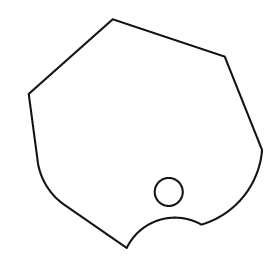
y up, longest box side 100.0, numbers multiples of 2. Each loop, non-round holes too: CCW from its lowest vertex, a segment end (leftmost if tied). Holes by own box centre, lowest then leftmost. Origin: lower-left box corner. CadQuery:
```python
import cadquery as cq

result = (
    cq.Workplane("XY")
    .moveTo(42.0, 0.0)
    .threePointArc((56.0, 12.0), (74.0, 10.0))
    .threePointArc((92.0, 22.0), (100.0, 42.0))
    .lineTo(84.0, 82.0)
    .lineTo(36.0, 98.0)
    .lineTo(0.0, 66.0)
    .lineTo(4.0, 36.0)
    .threePointArc((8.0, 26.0), (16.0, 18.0))
    .close()
    .moveTo(60.0, 24.0)
    .circle(6.0)
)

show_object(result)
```